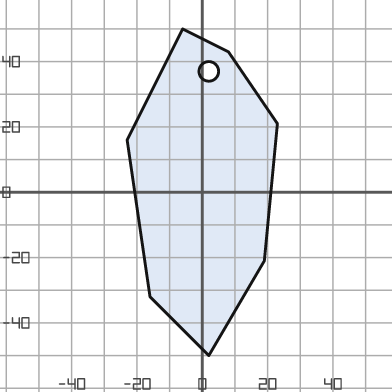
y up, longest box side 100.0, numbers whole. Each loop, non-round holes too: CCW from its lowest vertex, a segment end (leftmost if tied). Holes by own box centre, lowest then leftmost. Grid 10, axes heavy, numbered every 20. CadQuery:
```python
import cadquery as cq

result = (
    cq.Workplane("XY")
    .moveTo(2.0, -50.0)
    .lineTo(19.0, -21.0)
    .lineTo(23.0, 21.0)
    .lineTo(8.0, 43.0)
    .lineTo(-6.0, 50.0)
    .lineTo(-23.0, 16.0)
    .lineTo(-16.0, -32.0)
    .close()
    .moveTo(2.0, 37.0)
    .circle(3.0)
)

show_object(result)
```